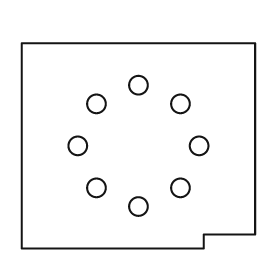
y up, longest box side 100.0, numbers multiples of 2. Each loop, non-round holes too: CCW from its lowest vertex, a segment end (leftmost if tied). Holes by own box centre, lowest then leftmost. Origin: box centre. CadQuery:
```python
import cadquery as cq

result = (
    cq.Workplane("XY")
    .moveTo(-50.0, -44.0)
    .lineTo(28.0, -44.0)
    .lineTo(28.0, -38.0)
    .lineTo(50.0, -38.0)
    .lineTo(50.0, 44.0)
    .lineTo(-50.0, 44.0)
    .close()
    .moveTo(0.0, -26.0)
    .circle(4.0)
    .moveTo(-18.0, -18.0)
    .circle(4.0)
    .moveTo(18.0, -18.0)
    .circle(4.0)
    .moveTo(-26.0, 0.0)
    .circle(4.0)
    .moveTo(26.0, 0.0)
    .circle(4.0)
    .moveTo(-18.0, 18.0)
    .circle(4.0)
    .moveTo(18.0, 18.0)
    .circle(4.0)
    .moveTo(0.0, 26.0)
    .circle(4.0)
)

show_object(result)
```